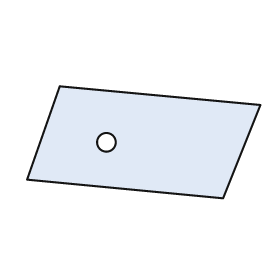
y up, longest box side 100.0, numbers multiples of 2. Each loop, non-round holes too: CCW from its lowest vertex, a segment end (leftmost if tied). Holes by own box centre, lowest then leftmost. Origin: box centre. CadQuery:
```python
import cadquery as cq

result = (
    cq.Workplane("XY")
    .moveTo(34.0, -24.0)
    .lineTo(50.0, 16.0)
    .lineTo(-36.0, 24.0)
    .lineTo(-50.0, -16.0)
    .close()
    .moveTo(-16.0, 0.0)
    .circle(4.0)
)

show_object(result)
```